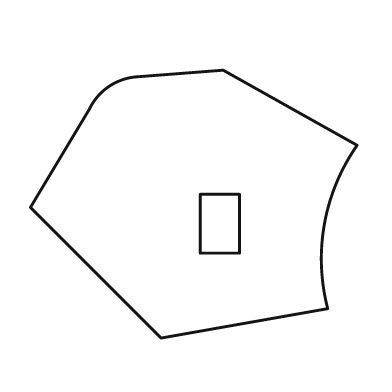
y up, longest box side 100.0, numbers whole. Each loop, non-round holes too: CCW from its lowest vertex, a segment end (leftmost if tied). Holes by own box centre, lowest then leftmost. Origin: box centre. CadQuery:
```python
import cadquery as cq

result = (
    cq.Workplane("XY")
    .moveTo(-10.0, -41.0)
    .lineTo(41.0, -32.0)
    .threePointArc((40.0, -6.0), (50.0, 18.0))
    .lineTo(9.0, 41.0)
    .lineTo(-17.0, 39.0)
    .threePointArc((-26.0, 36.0), (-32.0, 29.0))
    .lineTo(-50.0, -1.0)
    .close()
    .moveTo(2.0, -15.0)
    .lineTo(14.0, -15.0)
    .lineTo(14.0, 3.0)
    .lineTo(2.0, 3.0)
    .close()
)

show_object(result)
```